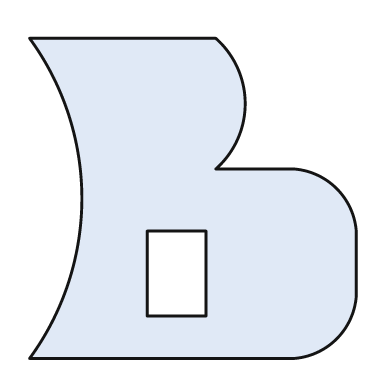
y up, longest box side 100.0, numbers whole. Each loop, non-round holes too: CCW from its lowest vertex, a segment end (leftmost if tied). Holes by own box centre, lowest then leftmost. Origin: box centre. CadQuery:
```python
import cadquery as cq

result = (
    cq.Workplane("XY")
    .moveTo(-50.0, -49.0)
    .lineTo(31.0, -49.0)
    .threePointArc((44.0, -43.0), (50.0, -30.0))
    .lineTo(50.0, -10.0)
    .threePointArc((44.0, 3.0), (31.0, 9.0))
    .lineTo(7.0, 9.0)
    .threePointArc((16.0, 29.0), (7.0, 49.0))
    .lineTo(-50.0, 49.0)
    .threePointArc((-34.0, 0.0), (-50.0, -49.0))
    .close()
    .moveTo(-14.0, -36.0)
    .lineTo(4.0, -36.0)
    .lineTo(4.0, -10.0)
    .lineTo(-14.0, -10.0)
    .close()
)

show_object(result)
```